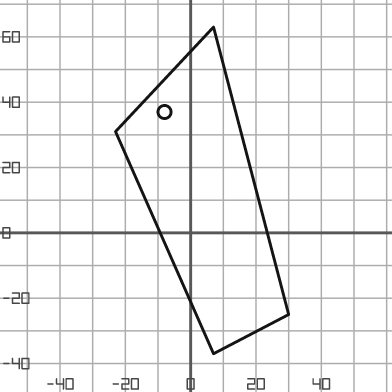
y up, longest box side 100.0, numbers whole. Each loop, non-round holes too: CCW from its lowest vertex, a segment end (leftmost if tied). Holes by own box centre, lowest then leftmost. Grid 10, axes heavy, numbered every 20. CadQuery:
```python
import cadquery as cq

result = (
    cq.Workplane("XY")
    .moveTo(7.0, -37.0)
    .lineTo(30.0, -25.0)
    .lineTo(7.0, 63.0)
    .lineTo(-23.0, 31.0)
    .close()
    .moveTo(-8.0, 37.0)
    .circle(2.0)
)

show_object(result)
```